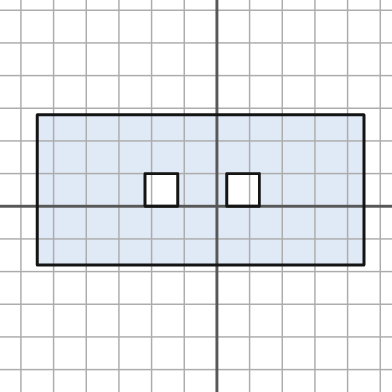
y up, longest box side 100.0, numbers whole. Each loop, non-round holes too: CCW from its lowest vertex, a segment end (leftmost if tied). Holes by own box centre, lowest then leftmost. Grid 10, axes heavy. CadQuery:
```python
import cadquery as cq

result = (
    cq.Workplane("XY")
    .moveTo(-55.0, -18.0)
    .lineTo(45.0, -18.0)
    .lineTo(45.0, 28.0)
    .lineTo(-55.0, 28.0)
    .close()
    .moveTo(-22.0, 0.0)
    .lineTo(-12.0, 0.0)
    .lineTo(-12.0, 10.0)
    .lineTo(-22.0, 10.0)
    .close()
    .moveTo(3.0, 0.0)
    .lineTo(13.0, 0.0)
    .lineTo(13.0, 10.0)
    .lineTo(3.0, 10.0)
    .close()
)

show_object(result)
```